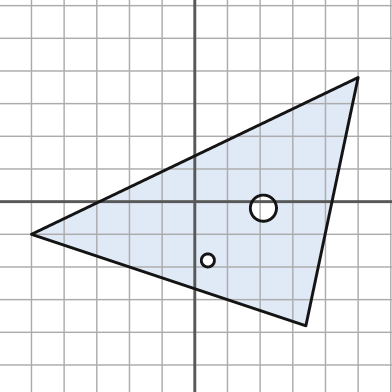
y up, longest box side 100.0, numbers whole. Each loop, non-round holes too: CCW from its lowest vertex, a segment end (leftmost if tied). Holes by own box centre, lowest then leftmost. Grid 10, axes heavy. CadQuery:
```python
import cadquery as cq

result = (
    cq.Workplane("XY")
    .moveTo(34.0, -38.0)
    .lineTo(50.0, 38.0)
    .lineTo(-50.0, -10.0)
    .close()
    .moveTo(4.0, -18.0)
    .circle(2.0)
    .moveTo(21.0, -2.0)
    .circle(4.0)
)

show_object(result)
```